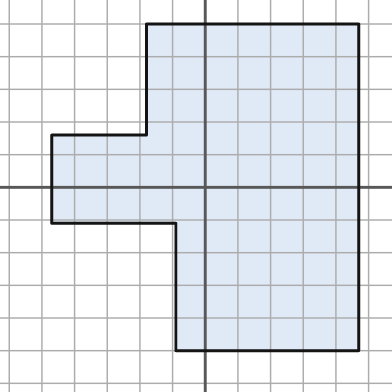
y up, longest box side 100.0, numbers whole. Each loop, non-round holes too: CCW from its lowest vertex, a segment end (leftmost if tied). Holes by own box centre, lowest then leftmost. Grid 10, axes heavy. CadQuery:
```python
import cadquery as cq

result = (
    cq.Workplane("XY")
    .moveTo(-9.0, -50.0)
    .lineTo(47.0, -50.0)
    .lineTo(47.0, 50.0)
    .lineTo(-18.0, 50.0)
    .lineTo(-18.0, 16.0)
    .lineTo(-47.0, 16.0)
    .lineTo(-47.0, -11.0)
    .lineTo(-9.0, -11.0)
    .close()
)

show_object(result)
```